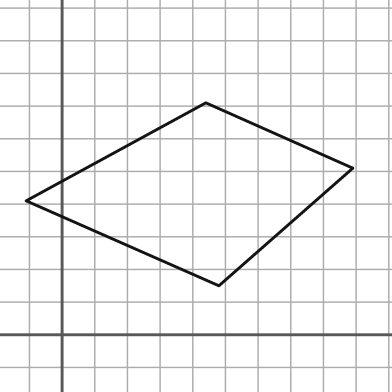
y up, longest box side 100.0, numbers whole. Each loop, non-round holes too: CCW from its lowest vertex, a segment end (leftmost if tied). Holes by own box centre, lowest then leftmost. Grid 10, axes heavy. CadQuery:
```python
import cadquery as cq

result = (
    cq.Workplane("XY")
    .moveTo(48.0, 15.0)
    .lineTo(89.0, 51.0)
    .lineTo(44.0, 71.0)
    .lineTo(-11.0, 41.0)
    .close()
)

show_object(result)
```